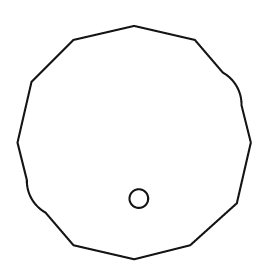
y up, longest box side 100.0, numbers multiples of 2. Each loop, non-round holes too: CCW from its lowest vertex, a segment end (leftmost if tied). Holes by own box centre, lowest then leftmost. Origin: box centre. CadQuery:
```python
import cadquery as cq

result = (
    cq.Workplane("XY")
    .moveTo(0.0, -50.0)
    .lineTo(24.0, -44.0)
    .lineTo(44.0, -26.0)
    .lineTo(50.0, 0.0)
    .lineTo(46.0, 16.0)
    .threePointArc((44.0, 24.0), (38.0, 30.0))
    .lineTo(26.0, 44.0)
    .lineTo(0.0, 50.0)
    .lineTo(-26.0, 44.0)
    .lineTo(-44.0, 26.0)
    .lineTo(-50.0, 0.0)
    .lineTo(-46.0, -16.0)
    .threePointArc((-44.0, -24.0), (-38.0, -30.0))
    .lineTo(-26.0, -44.0)
    .close()
    .moveTo(2.0, -24.0)
    .circle(4.0)
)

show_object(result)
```